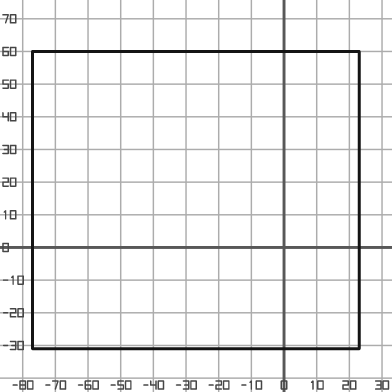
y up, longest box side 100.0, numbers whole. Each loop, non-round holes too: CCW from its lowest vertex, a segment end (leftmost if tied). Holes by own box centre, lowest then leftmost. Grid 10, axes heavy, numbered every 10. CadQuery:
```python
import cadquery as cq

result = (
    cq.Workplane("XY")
    .moveTo(-77.0, -31.0)
    .lineTo(23.0, -31.0)
    .lineTo(23.0, 60.0)
    .lineTo(-77.0, 60.0)
    .close()
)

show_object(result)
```